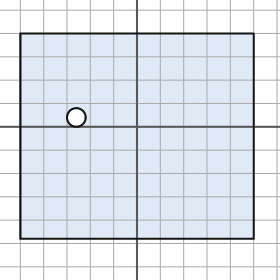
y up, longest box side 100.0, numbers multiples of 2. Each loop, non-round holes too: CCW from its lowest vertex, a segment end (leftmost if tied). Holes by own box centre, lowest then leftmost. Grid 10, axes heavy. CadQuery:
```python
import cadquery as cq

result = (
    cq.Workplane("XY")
    .moveTo(-50.0, -48.0)
    .lineTo(50.0, -48.0)
    .lineTo(50.0, 40.0)
    .lineTo(-50.0, 40.0)
    .close()
    .moveTo(-26.0, 4.0)
    .circle(4.0)
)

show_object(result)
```